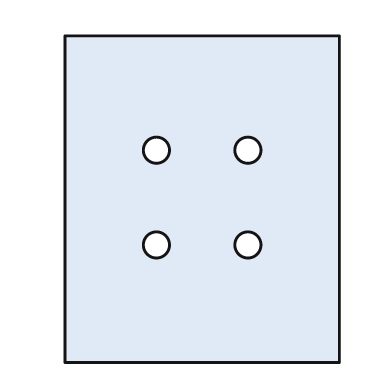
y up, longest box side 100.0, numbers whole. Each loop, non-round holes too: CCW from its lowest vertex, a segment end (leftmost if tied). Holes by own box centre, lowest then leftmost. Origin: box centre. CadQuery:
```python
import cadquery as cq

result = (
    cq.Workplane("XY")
    .moveTo(-42.0, -50.0)
    .lineTo(42.0, -50.0)
    .lineTo(42.0, 50.0)
    .lineTo(-42.0, 50.0)
    .close()
    .moveTo(-14.0, -14.0)
    .circle(4.0)
    .moveTo(14.0, -14.0)
    .circle(4.0)
    .moveTo(-14.0, 15.0)
    .circle(4.0)
    .moveTo(14.0, 15.0)
    .circle(4.0)
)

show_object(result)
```